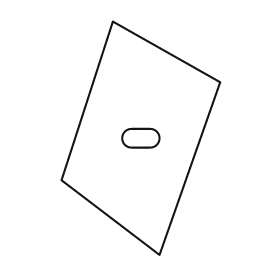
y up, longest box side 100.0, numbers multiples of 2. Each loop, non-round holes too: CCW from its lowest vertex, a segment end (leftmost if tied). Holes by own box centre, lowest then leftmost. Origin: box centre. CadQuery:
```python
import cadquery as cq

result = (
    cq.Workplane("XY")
    .moveTo(8.0, -50.0)
    .lineTo(34.0, 24.0)
    .lineTo(-12.0, 50.0)
    .lineTo(-34.0, -18.0)
    .close()
    .moveTo(-4.0, -4.0)
    .lineTo(4.0, -4.0)
    .threePointArc((8.0, 0.0), (4.0, 4.0))
    .lineTo(-4.0, 4.0)
    .threePointArc((-8.0, 0.0), (-4.0, -4.0))
    .close()
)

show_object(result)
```